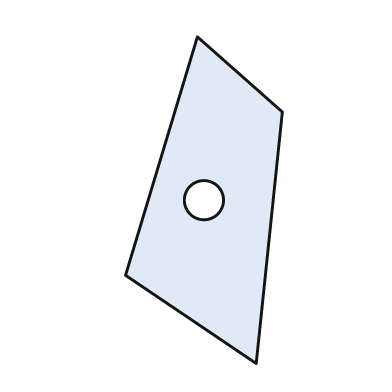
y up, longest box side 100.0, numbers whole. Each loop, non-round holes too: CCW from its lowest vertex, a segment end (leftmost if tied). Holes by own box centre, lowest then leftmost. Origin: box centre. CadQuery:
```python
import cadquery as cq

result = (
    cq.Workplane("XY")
    .moveTo(16.0, -50.0)
    .lineTo(24.0, 27.0)
    .lineTo(-2.0, 50.0)
    .lineTo(-24.0, -23.0)
    .close()
    .moveTo(0.0, 0.0)
    .circle(6.0)
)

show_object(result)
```